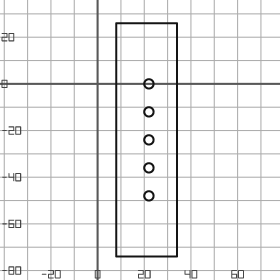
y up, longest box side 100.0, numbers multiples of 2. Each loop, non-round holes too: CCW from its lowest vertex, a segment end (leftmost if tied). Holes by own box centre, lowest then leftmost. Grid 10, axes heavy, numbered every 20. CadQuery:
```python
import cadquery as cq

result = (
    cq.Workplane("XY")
    .moveTo(8.0, -74.0)
    .lineTo(34.0, -74.0)
    .lineTo(34.0, 26.0)
    .lineTo(8.0, 26.0)
    .close()
    .moveTo(22.0, -48.0)
    .circle(2.0)
    .moveTo(22.0, -36.0)
    .circle(2.0)
    .moveTo(22.0, -24.0)
    .circle(2.0)
    .moveTo(22.0, -12.0)
    .circle(2.0)
    .moveTo(22.0, 0.0)
    .circle(2.0)
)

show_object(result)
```